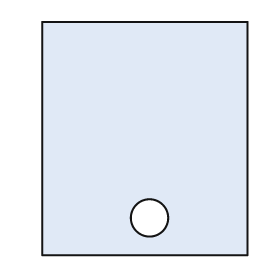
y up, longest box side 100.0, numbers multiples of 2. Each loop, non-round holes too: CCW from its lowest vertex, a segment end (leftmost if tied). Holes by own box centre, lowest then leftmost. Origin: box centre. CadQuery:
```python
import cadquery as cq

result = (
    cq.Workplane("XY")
    .moveTo(-44.0, -50.0)
    .lineTo(44.0, -50.0)
    .lineTo(44.0, 50.0)
    .lineTo(-44.0, 50.0)
    .close()
    .moveTo(2.0, -34.0)
    .circle(8.0)
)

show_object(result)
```